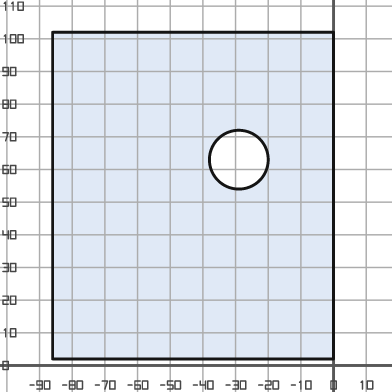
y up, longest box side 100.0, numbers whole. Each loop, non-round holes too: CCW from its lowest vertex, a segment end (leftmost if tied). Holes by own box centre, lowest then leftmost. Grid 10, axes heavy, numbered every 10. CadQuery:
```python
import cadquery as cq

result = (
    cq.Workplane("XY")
    .moveTo(-86.0, 2.0)
    .lineTo(0.0, 2.0)
    .lineTo(0.0, 102.0)
    .lineTo(-86.0, 102.0)
    .close()
    .moveTo(-29.0, 63.0)
    .circle(9.0)
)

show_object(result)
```